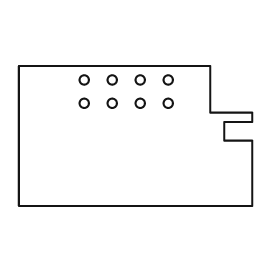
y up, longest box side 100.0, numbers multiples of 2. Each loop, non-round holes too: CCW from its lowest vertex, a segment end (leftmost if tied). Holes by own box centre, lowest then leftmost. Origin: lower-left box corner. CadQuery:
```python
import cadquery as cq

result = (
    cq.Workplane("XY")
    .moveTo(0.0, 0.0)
    .lineTo(100.0, 0.0)
    .lineTo(100.0, 28.0)
    .lineTo(88.0, 28.0)
    .lineTo(88.0, 36.0)
    .lineTo(100.0, 36.0)
    .lineTo(100.0, 40.0)
    .lineTo(82.0, 40.0)
    .lineTo(82.0, 60.0)
    .lineTo(0.0, 60.0)
    .close()
    .moveTo(28.0, 44.0)
    .circle(2.0)
    .moveTo(40.0, 44.0)
    .circle(2.0)
    .moveTo(52.0, 44.0)
    .circle(2.0)
    .moveTo(64.0, 44.0)
    .circle(2.0)
    .moveTo(28.0, 54.0)
    .circle(2.0)
    .moveTo(40.0, 54.0)
    .circle(2.0)
    .moveTo(52.0, 54.0)
    .circle(2.0)
    .moveTo(64.0, 54.0)
    .circle(2.0)
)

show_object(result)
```